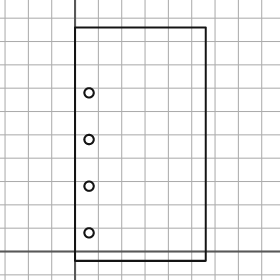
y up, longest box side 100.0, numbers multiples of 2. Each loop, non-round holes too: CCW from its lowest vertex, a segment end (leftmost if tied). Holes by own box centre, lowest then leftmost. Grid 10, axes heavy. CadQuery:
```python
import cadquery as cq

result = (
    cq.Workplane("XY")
    .moveTo(0.0, -4.0)
    .lineTo(56.0, -4.0)
    .lineTo(56.0, 96.0)
    .lineTo(0.0, 96.0)
    .close()
    .moveTo(6.0, 8.0)
    .circle(2.0)
    .moveTo(6.0, 28.0)
    .circle(2.0)
    .moveTo(6.0, 48.0)
    .circle(2.0)
    .moveTo(6.0, 68.0)
    .circle(2.0)
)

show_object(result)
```